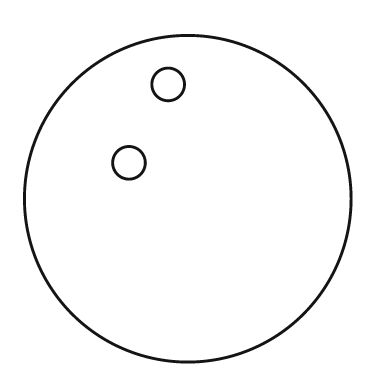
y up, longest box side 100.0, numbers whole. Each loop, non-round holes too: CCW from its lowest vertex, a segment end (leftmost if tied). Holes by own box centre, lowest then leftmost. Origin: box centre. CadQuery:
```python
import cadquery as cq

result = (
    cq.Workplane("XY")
    .moveTo(0.0, 0.0)
    .circle(50.0)
    .moveTo(-18.0, 11.0)
    .circle(5.0)
    .moveTo(-6.0, 35.0)
    .circle(5.0)
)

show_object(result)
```